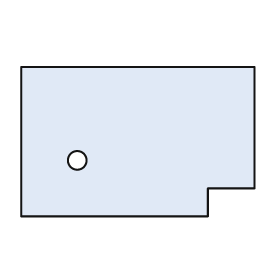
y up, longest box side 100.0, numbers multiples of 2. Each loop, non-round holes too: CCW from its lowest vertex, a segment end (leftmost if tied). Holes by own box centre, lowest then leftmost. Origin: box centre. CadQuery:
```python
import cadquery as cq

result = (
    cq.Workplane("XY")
    .moveTo(-50.0, -32.0)
    .lineTo(30.0, -32.0)
    .lineTo(30.0, -20.0)
    .lineTo(50.0, -20.0)
    .lineTo(50.0, 32.0)
    .lineTo(-50.0, 32.0)
    .close()
    .moveTo(-26.0, -8.0)
    .circle(4.0)
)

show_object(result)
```